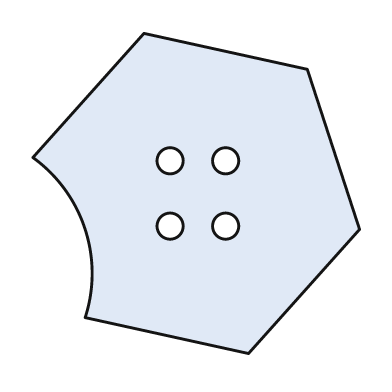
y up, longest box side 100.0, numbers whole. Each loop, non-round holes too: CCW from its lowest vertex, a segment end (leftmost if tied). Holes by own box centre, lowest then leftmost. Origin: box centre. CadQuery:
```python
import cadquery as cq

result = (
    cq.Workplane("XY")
    .moveTo(16.0, -49.0)
    .lineTo(50.0, -11.0)
    .lineTo(34.0, 38.0)
    .lineTo(-16.0, 49.0)
    .lineTo(-50.0, 11.0)
    .threePointArc((-34.0, -11.0), (-34.0, -38.0))
    .close()
    .moveTo(-8.0, -10.0)
    .circle(4.0)
    .moveTo(9.0, -10.0)
    .circle(4.0)
    .moveTo(-8.0, 10.0)
    .circle(4.0)
    .moveTo(9.0, 10.0)
    .circle(4.0)
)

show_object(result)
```